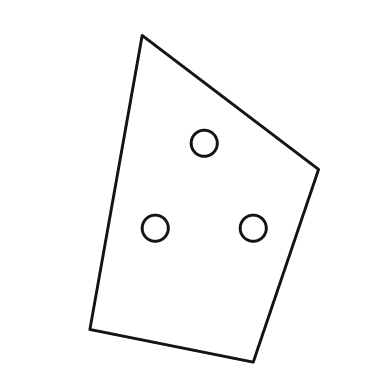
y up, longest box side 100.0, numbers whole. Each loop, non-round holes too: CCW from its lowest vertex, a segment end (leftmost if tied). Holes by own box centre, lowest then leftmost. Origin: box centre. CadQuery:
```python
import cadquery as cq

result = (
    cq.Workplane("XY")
    .moveTo(15.0, -50.0)
    .lineTo(35.0, 9.0)
    .lineTo(-19.0, 50.0)
    .lineTo(-35.0, -40.0)
    .close()
    .moveTo(-15.0, -9.0)
    .circle(4.0)
    .moveTo(15.0, -9.0)
    .circle(4.0)
    .moveTo(0.0, 17.0)
    .circle(4.0)
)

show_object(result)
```